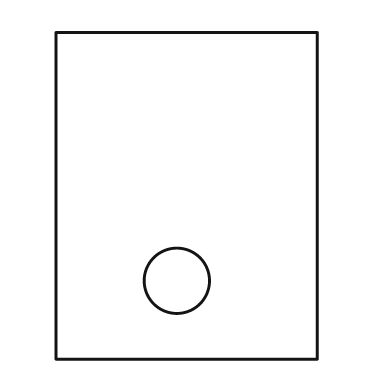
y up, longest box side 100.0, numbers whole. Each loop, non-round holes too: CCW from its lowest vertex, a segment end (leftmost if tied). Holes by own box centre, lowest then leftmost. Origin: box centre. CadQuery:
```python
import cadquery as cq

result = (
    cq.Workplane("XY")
    .moveTo(-40.0, -50.0)
    .lineTo(40.0, -50.0)
    .lineTo(40.0, 50.0)
    .lineTo(-40.0, 50.0)
    .close()
    .moveTo(-3.0, -26.0)
    .circle(10.0)
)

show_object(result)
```